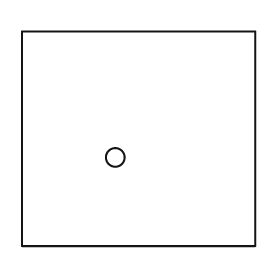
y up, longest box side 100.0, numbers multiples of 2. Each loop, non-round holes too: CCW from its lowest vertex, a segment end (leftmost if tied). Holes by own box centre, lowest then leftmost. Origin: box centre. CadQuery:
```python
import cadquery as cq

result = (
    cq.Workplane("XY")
    .moveTo(-50.0, -46.0)
    .lineTo(50.0, -46.0)
    .lineTo(50.0, 46.0)
    .lineTo(-50.0, 46.0)
    .close()
    .moveTo(-10.0, -8.0)
    .circle(4.0)
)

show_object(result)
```